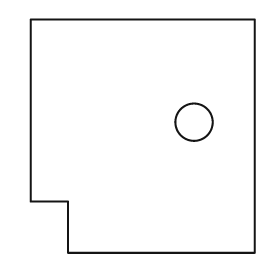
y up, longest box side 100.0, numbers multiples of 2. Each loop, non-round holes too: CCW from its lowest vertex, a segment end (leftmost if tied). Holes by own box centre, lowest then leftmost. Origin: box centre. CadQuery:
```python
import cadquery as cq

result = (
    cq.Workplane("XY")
    .moveTo(-32.0, -50.0)
    .lineTo(48.0, -50.0)
    .lineTo(48.0, 50.0)
    .lineTo(-48.0, 50.0)
    .lineTo(-48.0, -28.0)
    .lineTo(-32.0, -28.0)
    .close()
    .moveTo(22.0, 6.0)
    .circle(8.0)
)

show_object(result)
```